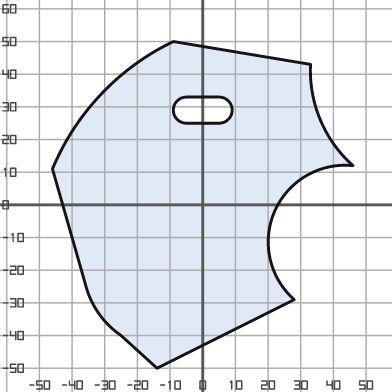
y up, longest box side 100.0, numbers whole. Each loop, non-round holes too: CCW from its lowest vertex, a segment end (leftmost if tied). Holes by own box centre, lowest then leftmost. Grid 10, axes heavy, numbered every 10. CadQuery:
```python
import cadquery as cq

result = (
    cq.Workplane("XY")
    .moveTo(-14.0, -50.0)
    .lineTo(28.0, -29.0)
    .threePointArc((22.0, -2.0), (46.0, 12.0))
    .threePointArc((36.0, 26.0), (33.0, 43.0))
    .lineTo(-9.0, 50.0)
    .threePointArc((-31.0, 34.0), (-46.0, 11.0))
    .lineTo(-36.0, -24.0)
    .threePointArc((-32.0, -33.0), (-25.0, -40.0))
    .close()
    .moveTo(-5.0, 25.0)
    .lineTo(5.0, 25.0)
    .threePointArc((9.0, 29.0), (5.0, 33.0))
    .lineTo(-5.0, 33.0)
    .threePointArc((-9.0, 29.0), (-5.0, 25.0))
    .close()
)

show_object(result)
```